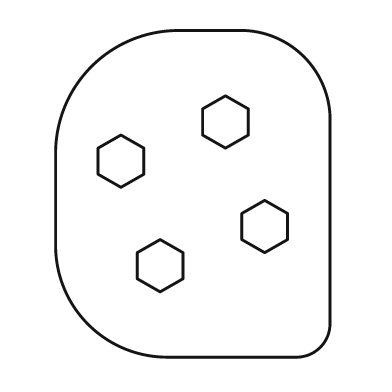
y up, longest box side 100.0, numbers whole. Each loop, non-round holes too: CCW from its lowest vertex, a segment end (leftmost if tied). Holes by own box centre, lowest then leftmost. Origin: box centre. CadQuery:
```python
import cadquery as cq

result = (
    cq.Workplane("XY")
    .moveTo(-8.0, -50.0)
    .lineTo(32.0, -50.0)
    .threePointArc((39.0, -47.0), (42.0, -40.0))
    .lineTo(42.0, 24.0)
    .threePointArc((34.0, 42.0), (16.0, 50.0))
    .lineTo(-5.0, 50.0)
    .threePointArc((-31.0, 39.0), (-42.0, 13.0))
    .lineTo(-42.0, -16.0)
    .threePointArc((-32.0, -40.0), (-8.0, -50.0))
    .close()
    .moveTo(-10.0, -30.0)
    .lineTo(-3.0, -26.0)
    .lineTo(-3.0, -18.0)
    .lineTo(-10.0, -14.0)
    .lineTo(-17.0, -18.0)
    .lineTo(-17.0, -26.0)
    .close()
    .moveTo(22.0, -18.0)
    .lineTo(29.0, -14.0)
    .lineTo(29.0, -6.0)
    .lineTo(22.0, -2.0)
    .lineTo(15.0, -6.0)
    .lineTo(15.0, -14.0)
    .close()
    .moveTo(-22.0, 2.0)
    .lineTo(-15.0, 6.0)
    .lineTo(-15.0, 14.0)
    .lineTo(-22.0, 18.0)
    .lineTo(-29.0, 14.0)
    .lineTo(-29.0, 6.0)
    .close()
    .moveTo(10.0, 14.0)
    .lineTo(17.0, 18.0)
    .lineTo(17.0, 26.0)
    .lineTo(10.0, 30.0)
    .lineTo(3.0, 26.0)
    .lineTo(3.0, 18.0)
    .close()
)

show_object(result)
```